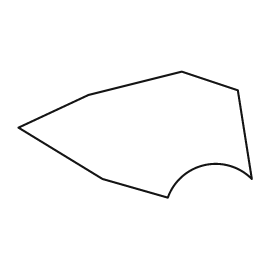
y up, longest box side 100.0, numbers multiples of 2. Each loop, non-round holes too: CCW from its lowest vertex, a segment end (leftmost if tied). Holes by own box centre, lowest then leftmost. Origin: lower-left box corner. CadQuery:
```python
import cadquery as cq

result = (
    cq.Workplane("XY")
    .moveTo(64.0, 0.0)
    .threePointArc((80.0, 14.0), (100.0, 8.0))
    .lineTo(94.0, 46.0)
    .lineTo(70.0, 54.0)
    .lineTo(30.0, 44.0)
    .lineTo(0.0, 30.0)
    .lineTo(36.0, 8.0)
    .close()
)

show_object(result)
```